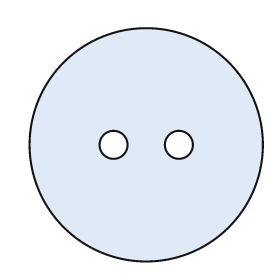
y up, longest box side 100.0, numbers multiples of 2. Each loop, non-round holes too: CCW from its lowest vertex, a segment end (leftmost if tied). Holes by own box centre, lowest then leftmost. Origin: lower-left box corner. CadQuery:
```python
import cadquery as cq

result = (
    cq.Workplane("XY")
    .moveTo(50.0, 50.0)
    .circle(50.0)
    .moveTo(36.0, 50.0)
    .circle(6.0)
    .moveTo(64.0, 50.0)
    .circle(6.0)
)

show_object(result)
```